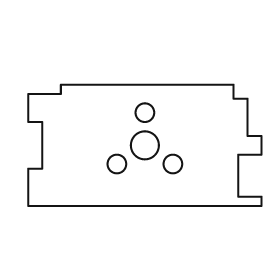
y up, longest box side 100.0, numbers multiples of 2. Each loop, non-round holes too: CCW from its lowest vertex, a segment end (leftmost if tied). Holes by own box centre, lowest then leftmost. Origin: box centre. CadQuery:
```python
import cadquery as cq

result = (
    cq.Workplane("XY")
    .moveTo(-50.0, -26.0)
    .lineTo(50.0, -26.0)
    .lineTo(50.0, -22.0)
    .lineTo(40.0, -22.0)
    .lineTo(40.0, -4.0)
    .lineTo(50.0, -4.0)
    .lineTo(50.0, 4.0)
    .lineTo(44.0, 4.0)
    .lineTo(44.0, 20.0)
    .lineTo(38.0, 20.0)
    .lineTo(38.0, 26.0)
    .lineTo(-36.0, 26.0)
    .lineTo(-36.0, 22.0)
    .lineTo(-50.0, 22.0)
    .lineTo(-50.0, 10.0)
    .lineTo(-44.0, 10.0)
    .lineTo(-44.0, -10.0)
    .lineTo(-50.0, -10.0)
    .close()
    .moveTo(-12.0, -8.0)
    .circle(4.0)
    .moveTo(12.0, -8.0)
    .circle(4.0)
    .moveTo(0.0, 0.0)
    .circle(6.0)
    .moveTo(0.0, 14.0)
    .circle(4.0)
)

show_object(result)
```